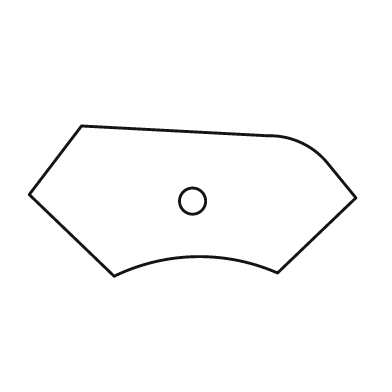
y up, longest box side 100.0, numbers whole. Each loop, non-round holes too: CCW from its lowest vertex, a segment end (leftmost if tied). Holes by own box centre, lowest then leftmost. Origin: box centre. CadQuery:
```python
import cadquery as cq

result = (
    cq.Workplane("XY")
    .moveTo(-24.0, -23.0)
    .threePointArc((1.0, -17.0), (26.0, -22.0))
    .lineTo(50.0, 1.0)
    .lineTo(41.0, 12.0)
    .threePointArc((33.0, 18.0), (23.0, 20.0))
    .lineTo(-34.0, 23.0)
    .lineTo(-50.0, 2.0)
    .close()
    .moveTo(0.0, 0.0)
    .circle(4.0)
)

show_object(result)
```